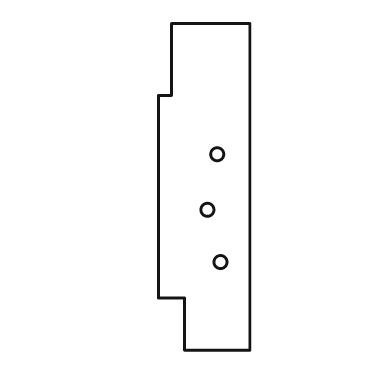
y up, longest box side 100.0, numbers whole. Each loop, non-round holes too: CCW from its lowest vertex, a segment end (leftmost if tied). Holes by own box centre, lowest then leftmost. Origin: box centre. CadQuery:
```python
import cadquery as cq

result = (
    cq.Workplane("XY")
    .moveTo(-6.0, -50.0)
    .lineTo(14.0, -50.0)
    .lineTo(14.0, 50.0)
    .lineTo(-10.0, 50.0)
    .lineTo(-10.0, 28.0)
    .lineTo(-14.0, 28.0)
    .lineTo(-14.0, -34.0)
    .lineTo(-6.0, -34.0)
    .close()
    .moveTo(5.0, -23.0)
    .circle(2.0)
    .moveTo(1.0, -7.0)
    .circle(2.0)
    .moveTo(4.0, 10.0)
    .circle(2.0)
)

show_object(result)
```